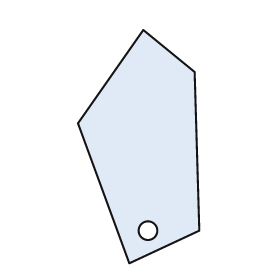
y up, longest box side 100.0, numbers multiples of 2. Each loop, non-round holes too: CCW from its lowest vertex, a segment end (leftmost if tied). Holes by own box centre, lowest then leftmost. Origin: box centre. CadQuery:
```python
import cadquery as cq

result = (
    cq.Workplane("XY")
    .moveTo(-4.0, -50.0)
    .lineTo(26.0, -36.0)
    .lineTo(24.0, 32.0)
    .lineTo(2.0, 50.0)
    .lineTo(-26.0, 10.0)
    .close()
    .moveTo(4.0, -36.0)
    .circle(4.0)
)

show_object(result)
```